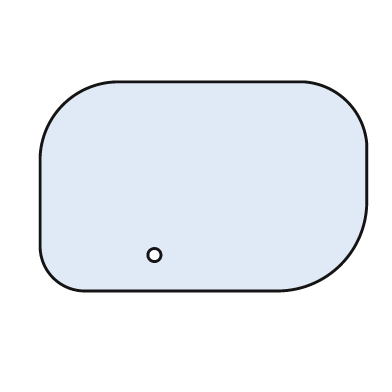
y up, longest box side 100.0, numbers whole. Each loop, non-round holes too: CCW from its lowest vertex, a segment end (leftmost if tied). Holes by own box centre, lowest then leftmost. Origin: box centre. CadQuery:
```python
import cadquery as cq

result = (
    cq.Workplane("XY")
    .moveTo(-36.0, -32.0)
    .lineTo(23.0, -32.0)
    .threePointArc((42.0, -24.0), (50.0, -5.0))
    .lineTo(50.0, 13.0)
    .threePointArc((44.0, 26.0), (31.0, 32.0))
    .lineTo(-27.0, 32.0)
    .threePointArc((-43.0, 25.0), (-50.0, 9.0))
    .lineTo(-50.0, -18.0)
    .threePointArc((-46.0, -28.0), (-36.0, -32.0))
    .close()
    .moveTo(-15.0, -21.0)
    .circle(2.0)
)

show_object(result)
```